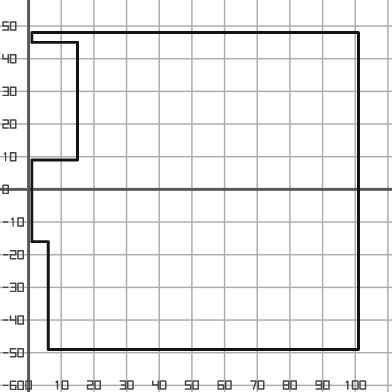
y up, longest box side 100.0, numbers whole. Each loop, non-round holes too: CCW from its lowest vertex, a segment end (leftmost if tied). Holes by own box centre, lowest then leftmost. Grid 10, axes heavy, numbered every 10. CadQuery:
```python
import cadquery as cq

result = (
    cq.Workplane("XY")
    .moveTo(6.0, -49.0)
    .lineTo(101.0, -49.0)
    .lineTo(101.0, 48.0)
    .lineTo(1.0, 48.0)
    .lineTo(1.0, 45.0)
    .lineTo(15.0, 45.0)
    .lineTo(15.0, 9.0)
    .lineTo(1.0, 9.0)
    .lineTo(1.0, -16.0)
    .lineTo(6.0, -16.0)
    .close()
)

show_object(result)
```